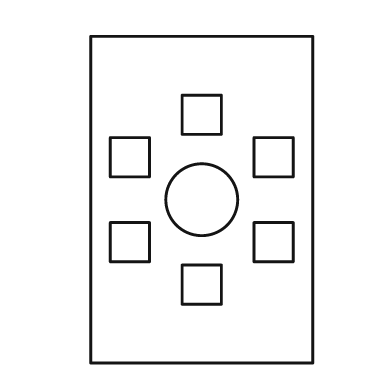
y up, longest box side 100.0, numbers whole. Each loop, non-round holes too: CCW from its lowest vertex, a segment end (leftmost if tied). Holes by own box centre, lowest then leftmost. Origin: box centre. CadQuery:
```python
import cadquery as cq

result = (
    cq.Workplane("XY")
    .moveTo(-34.0, -50.0)
    .lineTo(34.0, -50.0)
    .lineTo(34.0, 50.0)
    .lineTo(-34.0, 50.0)
    .close()
    .moveTo(-6.0, -32.0)
    .lineTo(6.0, -32.0)
    .lineTo(6.0, -20.0)
    .lineTo(-6.0, -20.0)
    .close()
    .moveTo(-28.0, -19.0)
    .lineTo(-16.0, -19.0)
    .lineTo(-16.0, -7.0)
    .lineTo(-28.0, -7.0)
    .close()
    .moveTo(16.0, -19.0)
    .lineTo(28.0, -19.0)
    .lineTo(28.0, -7.0)
    .lineTo(16.0, -7.0)
    .close()
    .moveTo(0.0, 0.0)
    .circle(11.0)
    .moveTo(-28.0, 7.0)
    .lineTo(-16.0, 7.0)
    .lineTo(-16.0, 19.0)
    .lineTo(-28.0, 19.0)
    .close()
    .moveTo(16.0, 7.0)
    .lineTo(28.0, 7.0)
    .lineTo(28.0, 19.0)
    .lineTo(16.0, 19.0)
    .close()
    .moveTo(-6.0, 20.0)
    .lineTo(6.0, 20.0)
    .lineTo(6.0, 32.0)
    .lineTo(-6.0, 32.0)
    .close()
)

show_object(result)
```